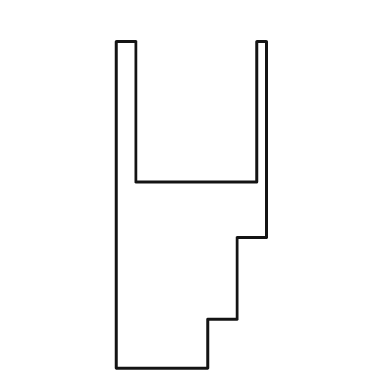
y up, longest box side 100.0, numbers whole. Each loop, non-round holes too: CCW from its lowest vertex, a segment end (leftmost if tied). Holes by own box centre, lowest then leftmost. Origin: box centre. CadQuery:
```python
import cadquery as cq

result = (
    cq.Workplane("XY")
    .moveTo(-23.0, -50.0)
    .lineTo(5.0, -50.0)
    .lineTo(5.0, -35.0)
    .lineTo(14.0, -35.0)
    .lineTo(14.0, -10.0)
    .lineTo(23.0, -10.0)
    .lineTo(23.0, 50.0)
    .lineTo(20.0, 50.0)
    .lineTo(20.0, 7.0)
    .lineTo(-17.0, 7.0)
    .lineTo(-17.0, 50.0)
    .lineTo(-23.0, 50.0)
    .close()
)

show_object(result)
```